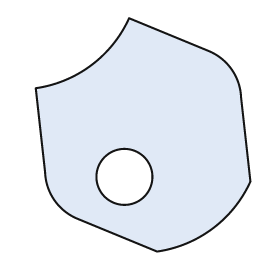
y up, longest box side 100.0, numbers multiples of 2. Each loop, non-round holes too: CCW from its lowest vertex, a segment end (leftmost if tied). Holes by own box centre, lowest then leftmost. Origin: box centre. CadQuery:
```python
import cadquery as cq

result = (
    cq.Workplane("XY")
    .moveTo(6.0, -50.0)
    .threePointArc((30.0, -40.0), (46.0, -20.0))
    .lineTo(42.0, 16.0)
    .threePointArc((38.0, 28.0), (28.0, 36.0))
    .lineTo(-6.0, 50.0)
    .threePointArc((-22.0, 30.0), (-46.0, 20.0))
    .lineTo(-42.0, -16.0)
    .threePointArc((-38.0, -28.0), (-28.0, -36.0))
    .close()
    .moveTo(-8.0, -18.0)
    .circle(12.0)
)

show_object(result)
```